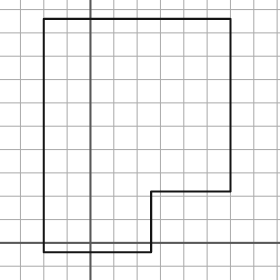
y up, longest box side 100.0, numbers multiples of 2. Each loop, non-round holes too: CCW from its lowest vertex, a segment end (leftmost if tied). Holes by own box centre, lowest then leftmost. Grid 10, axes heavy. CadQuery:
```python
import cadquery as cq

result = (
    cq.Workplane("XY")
    .moveTo(-20.0, -4.0)
    .lineTo(26.0, -4.0)
    .lineTo(26.0, 22.0)
    .lineTo(60.0, 22.0)
    .lineTo(60.0, 96.0)
    .lineTo(-20.0, 96.0)
    .close()
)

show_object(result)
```